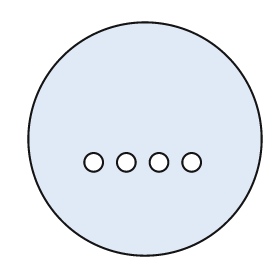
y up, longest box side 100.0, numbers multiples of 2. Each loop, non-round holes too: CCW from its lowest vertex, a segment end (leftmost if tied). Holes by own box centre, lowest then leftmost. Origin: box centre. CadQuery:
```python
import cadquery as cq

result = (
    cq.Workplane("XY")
    .moveTo(0.0, 0.0)
    .circle(50.0)
    .moveTo(-22.0, -10.0)
    .circle(4.0)
    .moveTo(-8.0, -10.0)
    .circle(4.0)
    .moveTo(6.0, -10.0)
    .circle(4.0)
    .moveTo(20.0, -10.0)
    .circle(4.0)
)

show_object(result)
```